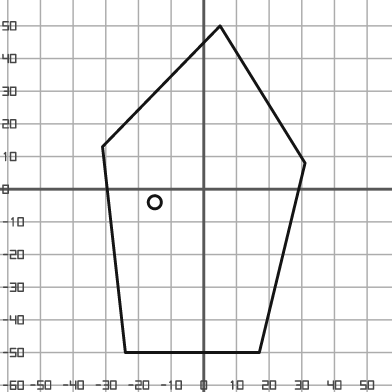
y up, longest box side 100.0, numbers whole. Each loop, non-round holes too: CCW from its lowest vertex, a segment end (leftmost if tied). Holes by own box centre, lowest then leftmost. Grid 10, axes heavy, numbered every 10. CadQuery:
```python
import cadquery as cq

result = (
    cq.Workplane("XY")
    .moveTo(-24.0, -50.0)
    .lineTo(17.0, -50.0)
    .lineTo(31.0, 8.0)
    .lineTo(5.0, 50.0)
    .lineTo(-31.0, 13.0)
    .close()
    .moveTo(-15.0, -4.0)
    .circle(2.0)
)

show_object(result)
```